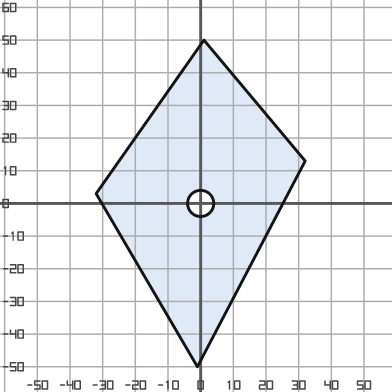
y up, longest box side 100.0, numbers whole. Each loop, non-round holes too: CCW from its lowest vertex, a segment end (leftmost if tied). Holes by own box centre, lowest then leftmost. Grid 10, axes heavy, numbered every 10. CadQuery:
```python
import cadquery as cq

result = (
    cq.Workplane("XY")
    .moveTo(-1.0, -50.0)
    .lineTo(32.0, 13.0)
    .lineTo(1.0, 50.0)
    .lineTo(-32.0, 3.0)
    .close()
    .moveTo(0.0, 0.0)
    .circle(4.0)
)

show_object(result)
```